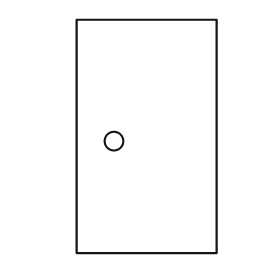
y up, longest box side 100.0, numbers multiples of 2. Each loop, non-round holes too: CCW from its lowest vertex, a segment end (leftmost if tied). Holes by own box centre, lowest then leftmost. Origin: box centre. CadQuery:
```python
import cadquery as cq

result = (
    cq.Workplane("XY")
    .moveTo(-30.0, -50.0)
    .lineTo(30.0, -50.0)
    .lineTo(30.0, 50.0)
    .lineTo(-30.0, 50.0)
    .close()
    .moveTo(-14.0, -2.0)
    .circle(4.0)
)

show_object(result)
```